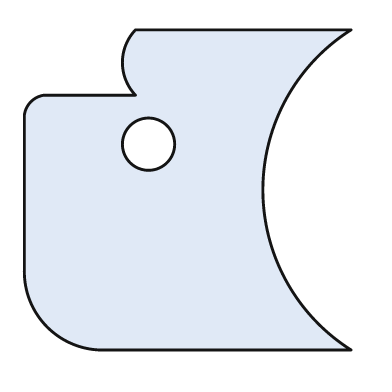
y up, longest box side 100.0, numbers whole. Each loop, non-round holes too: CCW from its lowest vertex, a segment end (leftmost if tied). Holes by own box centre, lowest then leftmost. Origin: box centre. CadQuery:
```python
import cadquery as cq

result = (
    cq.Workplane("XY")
    .moveTo(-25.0, -49.0)
    .lineTo(50.0, -49.0)
    .threePointArc((23.0, 0.0), (50.0, 49.0))
    .lineTo(-16.0, 49.0)
    .threePointArc((-20.0, 39.0), (-16.0, 29.0))
    .lineTo(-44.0, 29.0)
    .threePointArc((-48.0, 27.0), (-50.0, 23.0))
    .lineTo(-50.0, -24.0)
    .threePointArc((-43.0, -42.0), (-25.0, -49.0))
    .close()
    .moveTo(-12.0, 14.0)
    .circle(8.0)
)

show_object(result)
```